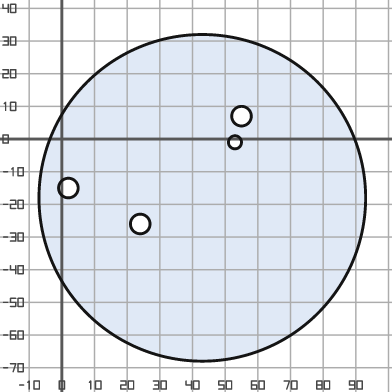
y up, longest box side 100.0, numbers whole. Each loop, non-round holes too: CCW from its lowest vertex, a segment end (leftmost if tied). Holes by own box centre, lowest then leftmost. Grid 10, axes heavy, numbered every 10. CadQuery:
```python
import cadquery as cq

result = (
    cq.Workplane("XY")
    .moveTo(43.0, -18.0)
    .circle(50.0)
    .moveTo(24.0, -26.0)
    .circle(3.0)
    .moveTo(2.0, -15.0)
    .circle(3.0)
    .moveTo(53.0, -1.0)
    .circle(2.0)
    .moveTo(55.0, 7.0)
    .circle(3.0)
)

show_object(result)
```